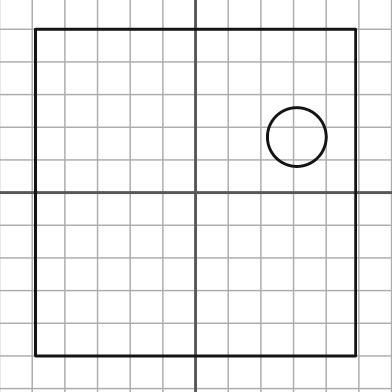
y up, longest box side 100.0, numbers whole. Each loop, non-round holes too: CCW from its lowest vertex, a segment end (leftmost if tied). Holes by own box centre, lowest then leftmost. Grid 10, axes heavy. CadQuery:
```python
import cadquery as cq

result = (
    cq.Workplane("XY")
    .moveTo(-49.0, -50.0)
    .lineTo(49.0, -50.0)
    .lineTo(49.0, 50.0)
    .lineTo(-49.0, 50.0)
    .close()
    .moveTo(31.0, 17.0)
    .circle(9.0)
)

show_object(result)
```